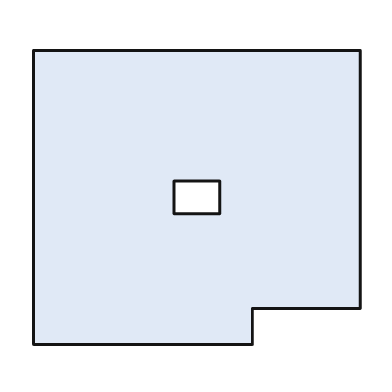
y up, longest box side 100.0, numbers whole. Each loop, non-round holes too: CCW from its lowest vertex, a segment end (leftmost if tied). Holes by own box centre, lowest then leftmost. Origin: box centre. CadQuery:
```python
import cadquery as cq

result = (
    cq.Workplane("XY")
    .moveTo(-50.0, -45.0)
    .lineTo(17.0, -45.0)
    .lineTo(17.0, -34.0)
    .lineTo(50.0, -34.0)
    .lineTo(50.0, 45.0)
    .lineTo(-50.0, 45.0)
    .close()
    .moveTo(-7.0, -5.0)
    .lineTo(7.0, -5.0)
    .lineTo(7.0, 5.0)
    .lineTo(-7.0, 5.0)
    .close()
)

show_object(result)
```